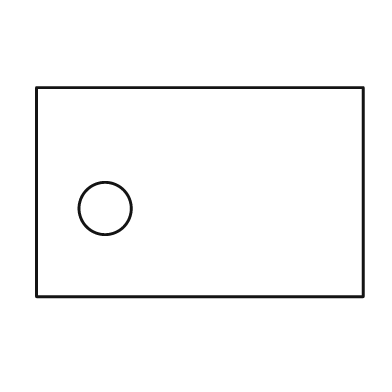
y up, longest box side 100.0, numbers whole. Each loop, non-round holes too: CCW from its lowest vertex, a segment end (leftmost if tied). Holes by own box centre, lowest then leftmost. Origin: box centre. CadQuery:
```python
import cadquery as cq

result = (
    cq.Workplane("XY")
    .moveTo(-50.0, -32.0)
    .lineTo(50.0, -32.0)
    .lineTo(50.0, 32.0)
    .lineTo(-50.0, 32.0)
    .close()
    .moveTo(-29.0, -5.0)
    .circle(8.0)
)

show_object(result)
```